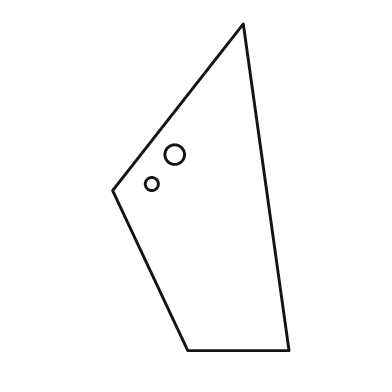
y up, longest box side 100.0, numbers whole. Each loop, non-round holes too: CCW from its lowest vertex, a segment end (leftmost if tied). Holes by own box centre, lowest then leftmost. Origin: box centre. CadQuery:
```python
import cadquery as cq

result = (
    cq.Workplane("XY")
    .moveTo(-4.0, -50.0)
    .lineTo(27.0, -50.0)
    .lineTo(13.0, 50.0)
    .lineTo(-27.0, -1.0)
    .close()
    .moveTo(-15.0, 1.0)
    .circle(2.0)
    .moveTo(-8.0, 10.0)
    .circle(3.0)
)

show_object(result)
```